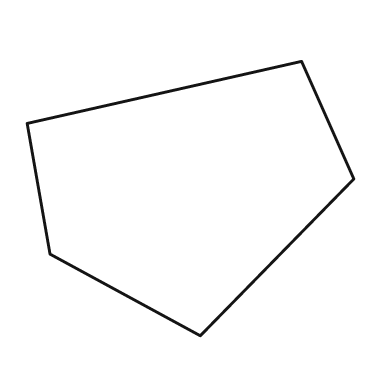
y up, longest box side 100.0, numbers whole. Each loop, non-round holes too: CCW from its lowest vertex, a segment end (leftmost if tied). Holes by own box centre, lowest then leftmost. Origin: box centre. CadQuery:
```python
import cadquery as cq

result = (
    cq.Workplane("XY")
    .moveTo(3.0, -42.0)
    .lineTo(50.0, 6.0)
    .lineTo(34.0, 42.0)
    .lineTo(-50.0, 23.0)
    .lineTo(-43.0, -17.0)
    .close()
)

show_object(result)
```